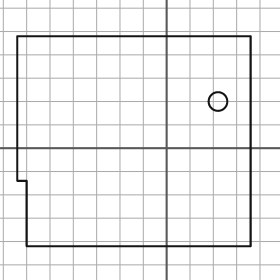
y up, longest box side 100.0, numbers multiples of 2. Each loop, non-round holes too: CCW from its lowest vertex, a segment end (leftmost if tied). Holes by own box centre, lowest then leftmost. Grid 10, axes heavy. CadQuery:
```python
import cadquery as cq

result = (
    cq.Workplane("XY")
    .moveTo(-60.0, -42.0)
    .lineTo(36.0, -42.0)
    .lineTo(36.0, 48.0)
    .lineTo(-64.0, 48.0)
    .lineTo(-64.0, -14.0)
    .lineTo(-60.0, -14.0)
    .close()
    .moveTo(22.0, 20.0)
    .circle(4.0)
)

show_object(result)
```